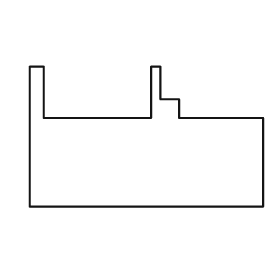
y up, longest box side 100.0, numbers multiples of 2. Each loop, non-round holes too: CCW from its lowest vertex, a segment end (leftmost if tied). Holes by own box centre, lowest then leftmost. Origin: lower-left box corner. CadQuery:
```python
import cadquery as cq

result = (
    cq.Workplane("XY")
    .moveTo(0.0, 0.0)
    .lineTo(100.0, 0.0)
    .lineTo(100.0, 38.0)
    .lineTo(64.0, 38.0)
    .lineTo(64.0, 46.0)
    .lineTo(56.0, 46.0)
    .lineTo(56.0, 60.0)
    .lineTo(52.0, 60.0)
    .lineTo(52.0, 38.0)
    .lineTo(6.0, 38.0)
    .lineTo(6.0, 60.0)
    .lineTo(0.0, 60.0)
    .close()
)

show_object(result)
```